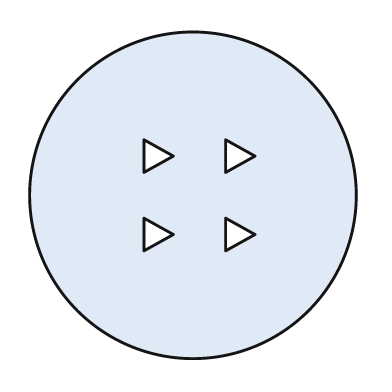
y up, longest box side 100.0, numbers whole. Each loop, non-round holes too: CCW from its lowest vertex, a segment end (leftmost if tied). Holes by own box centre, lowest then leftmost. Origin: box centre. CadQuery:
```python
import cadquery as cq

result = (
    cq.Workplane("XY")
    .moveTo(0.0, 0.0)
    .circle(50.0)
    .moveTo(-15.0, -17.0)
    .lineTo(-6.0, -12.0)
    .lineTo(-15.0, -7.0)
    .close()
    .moveTo(10.0, -17.0)
    .lineTo(19.0, -12.0)
    .lineTo(10.0, -7.0)
    .close()
    .moveTo(-15.0, 7.0)
    .lineTo(-6.0, 12.0)
    .lineTo(-15.0, 17.0)
    .close()
    .moveTo(10.0, 7.0)
    .lineTo(19.0, 12.0)
    .lineTo(10.0, 17.0)
    .close()
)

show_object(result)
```